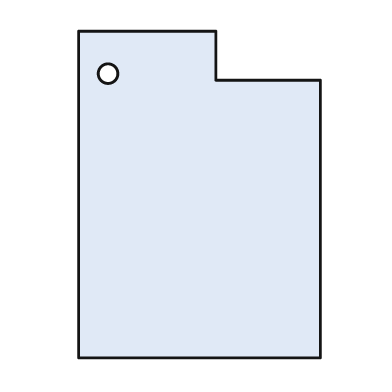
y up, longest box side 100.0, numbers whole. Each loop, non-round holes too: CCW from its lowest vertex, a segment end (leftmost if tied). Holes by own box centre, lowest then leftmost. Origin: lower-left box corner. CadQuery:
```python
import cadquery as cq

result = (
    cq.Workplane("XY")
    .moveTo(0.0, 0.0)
    .lineTo(74.0, 0.0)
    .lineTo(74.0, 85.0)
    .lineTo(42.0, 85.0)
    .lineTo(42.0, 100.0)
    .lineTo(0.0, 100.0)
    .close()
    .moveTo(9.0, 87.0)
    .circle(3.0)
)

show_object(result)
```